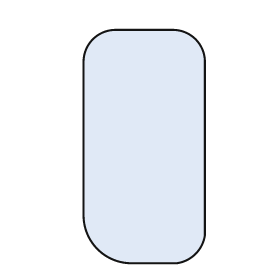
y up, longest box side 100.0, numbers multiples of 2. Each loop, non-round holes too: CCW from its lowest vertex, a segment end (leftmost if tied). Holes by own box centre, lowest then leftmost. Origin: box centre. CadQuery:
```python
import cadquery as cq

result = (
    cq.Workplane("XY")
    .moveTo(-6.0, -50.0)
    .lineTo(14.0, -50.0)
    .threePointArc((22.0, -46.0), (26.0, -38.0))
    .lineTo(26.0, 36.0)
    .threePointArc((22.0, 46.0), (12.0, 50.0))
    .lineTo(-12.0, 50.0)
    .threePointArc((-22.0, 46.0), (-26.0, 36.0))
    .lineTo(-26.0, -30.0)
    .threePointArc((-20.0, -44.0), (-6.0, -50.0))
    .close()
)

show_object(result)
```